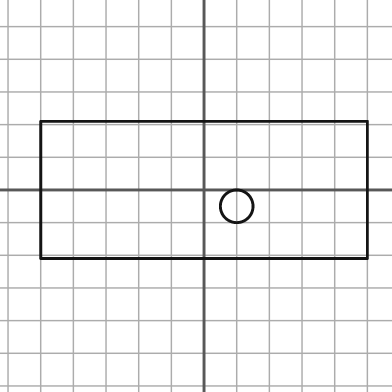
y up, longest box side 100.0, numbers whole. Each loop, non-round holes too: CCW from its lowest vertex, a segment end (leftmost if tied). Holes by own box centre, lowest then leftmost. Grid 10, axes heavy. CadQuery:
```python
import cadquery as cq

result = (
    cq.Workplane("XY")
    .moveTo(-50.0, -21.0)
    .lineTo(50.0, -21.0)
    .lineTo(50.0, 21.0)
    .lineTo(-50.0, 21.0)
    .close()
    .moveTo(10.0, -5.0)
    .circle(5.0)
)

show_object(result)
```